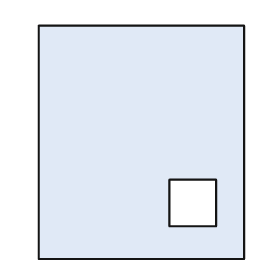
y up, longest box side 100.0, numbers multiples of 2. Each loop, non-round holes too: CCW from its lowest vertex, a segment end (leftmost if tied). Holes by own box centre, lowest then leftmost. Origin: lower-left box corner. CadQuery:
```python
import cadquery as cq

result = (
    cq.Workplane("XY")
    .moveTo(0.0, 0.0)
    .lineTo(88.0, 0.0)
    .lineTo(88.0, 100.0)
    .lineTo(0.0, 100.0)
    .close()
    .moveTo(56.0, 14.0)
    .lineTo(76.0, 14.0)
    .lineTo(76.0, 34.0)
    .lineTo(56.0, 34.0)
    .close()
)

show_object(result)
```